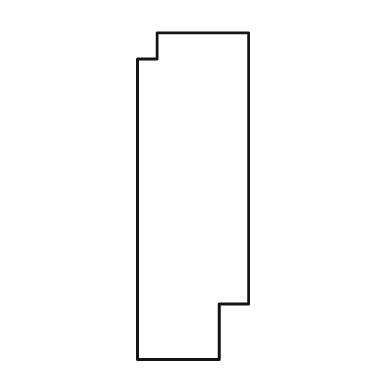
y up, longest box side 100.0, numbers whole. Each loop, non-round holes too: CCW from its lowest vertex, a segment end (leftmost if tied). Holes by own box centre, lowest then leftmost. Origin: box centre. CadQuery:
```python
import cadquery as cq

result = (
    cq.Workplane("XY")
    .moveTo(-17.0, -50.0)
    .lineTo(8.0, -50.0)
    .lineTo(8.0, -33.0)
    .lineTo(17.0, -33.0)
    .lineTo(17.0, 50.0)
    .lineTo(-11.0, 50.0)
    .lineTo(-11.0, 42.0)
    .lineTo(-17.0, 42.0)
    .close()
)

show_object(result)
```